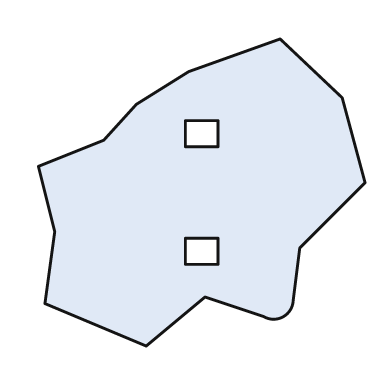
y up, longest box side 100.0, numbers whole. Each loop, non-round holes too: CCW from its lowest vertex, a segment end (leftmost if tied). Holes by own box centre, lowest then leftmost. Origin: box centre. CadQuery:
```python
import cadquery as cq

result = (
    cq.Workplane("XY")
    .moveTo(-17.0, -47.0)
    .lineTo(1.0, -32.0)
    .lineTo(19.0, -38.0)
    .threePointArc((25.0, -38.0), (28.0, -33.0))
    .lineTo(30.0, -17.0)
    .lineTo(50.0, 3.0)
    .lineTo(43.0, 29.0)
    .lineTo(24.0, 47.0)
    .lineTo(-4.0, 37.0)
    .lineTo(-20.0, 27.0)
    .lineTo(-30.0, 16.0)
    .lineTo(-50.0, 8.0)
    .lineTo(-45.0, -12.0)
    .lineTo(-48.0, -34.0)
    .close()
    .moveTo(-5.0, -22.0)
    .lineTo(5.0, -22.0)
    .lineTo(5.0, -14.0)
    .lineTo(-5.0, -14.0)
    .close()
    .moveTo(-5.0, 14.0)
    .lineTo(5.0, 14.0)
    .lineTo(5.0, 22.0)
    .lineTo(-5.0, 22.0)
    .close()
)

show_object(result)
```